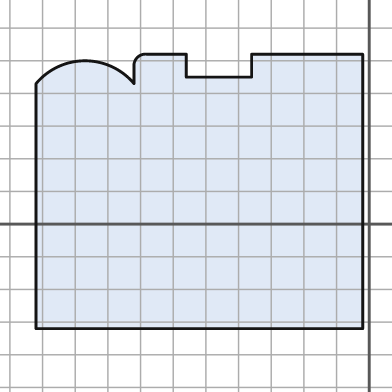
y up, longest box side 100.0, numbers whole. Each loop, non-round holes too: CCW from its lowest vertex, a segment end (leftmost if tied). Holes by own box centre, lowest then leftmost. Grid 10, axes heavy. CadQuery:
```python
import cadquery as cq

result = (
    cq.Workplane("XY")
    .moveTo(-102.0, -32.0)
    .lineTo(-2.0, -32.0)
    .lineTo(-2.0, 52.0)
    .lineTo(-36.0, 52.0)
    .lineTo(-36.0, 45.0)
    .lineTo(-56.0, 45.0)
    .lineTo(-56.0, 52.0)
    .lineTo(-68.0, 52.0)
    .threePointArc((-71.0, 51.0), (-72.0, 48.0))
    .lineTo(-72.0, 43.0)
    .threePointArc((-87.0, 50.0), (-102.0, 43.0))
    .close()
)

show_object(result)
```